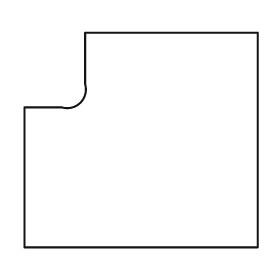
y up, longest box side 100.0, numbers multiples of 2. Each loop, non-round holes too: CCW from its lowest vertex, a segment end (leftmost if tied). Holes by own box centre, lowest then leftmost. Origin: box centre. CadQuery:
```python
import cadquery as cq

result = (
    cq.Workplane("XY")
    .moveTo(-50.0, -46.0)
    .lineTo(50.0, -46.0)
    .lineTo(50.0, 46.0)
    .lineTo(-24.0, 46.0)
    .lineTo(-24.0, 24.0)
    .threePointArc((-26.0, 16.0), (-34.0, 14.0))
    .lineTo(-50.0, 14.0)
    .close()
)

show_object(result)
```